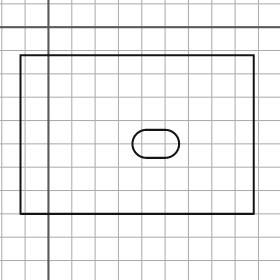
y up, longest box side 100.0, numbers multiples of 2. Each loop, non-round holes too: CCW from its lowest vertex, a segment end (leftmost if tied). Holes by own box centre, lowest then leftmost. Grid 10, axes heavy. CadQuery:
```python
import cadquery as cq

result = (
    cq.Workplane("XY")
    .moveTo(-12.0, -80.0)
    .lineTo(88.0, -80.0)
    .lineTo(88.0, -12.0)
    .lineTo(-12.0, -12.0)
    .close()
    .moveTo(42.0, -56.0)
    .lineTo(50.0, -56.0)
    .threePointArc((56.0, -50.0), (50.0, -44.0))
    .lineTo(42.0, -44.0)
    .threePointArc((36.0, -50.0), (42.0, -56.0))
    .close()
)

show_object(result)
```